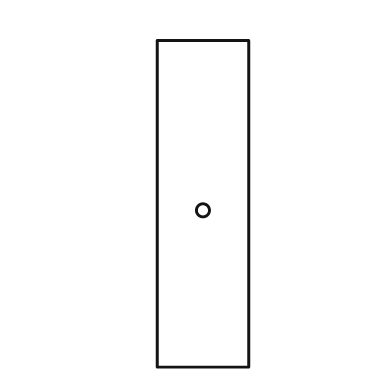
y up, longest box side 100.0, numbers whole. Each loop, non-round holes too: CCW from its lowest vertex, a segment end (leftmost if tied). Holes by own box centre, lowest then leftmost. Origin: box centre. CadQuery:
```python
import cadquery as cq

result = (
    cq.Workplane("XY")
    .moveTo(-14.0, -50.0)
    .lineTo(14.0, -50.0)
    .lineTo(14.0, 50.0)
    .lineTo(-14.0, 50.0)
    .close()
    .moveTo(0.0, -2.0)
    .circle(2.0)
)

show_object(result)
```